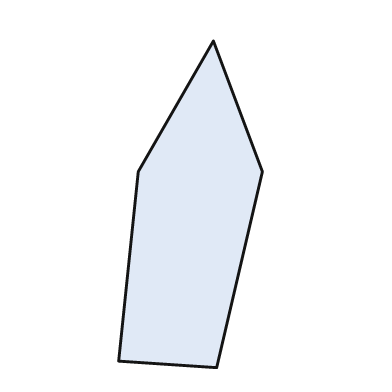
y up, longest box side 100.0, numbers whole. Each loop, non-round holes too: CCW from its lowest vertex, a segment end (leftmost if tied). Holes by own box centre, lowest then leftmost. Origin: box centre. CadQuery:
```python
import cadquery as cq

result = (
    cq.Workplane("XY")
    .moveTo(8.0, -50.0)
    .lineTo(22.0, 10.0)
    .lineTo(7.0, 50.0)
    .lineTo(-16.0, 10.0)
    .lineTo(-22.0, -48.0)
    .close()
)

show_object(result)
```